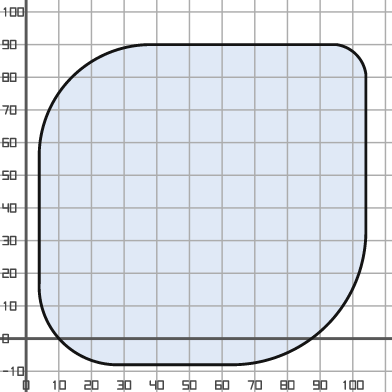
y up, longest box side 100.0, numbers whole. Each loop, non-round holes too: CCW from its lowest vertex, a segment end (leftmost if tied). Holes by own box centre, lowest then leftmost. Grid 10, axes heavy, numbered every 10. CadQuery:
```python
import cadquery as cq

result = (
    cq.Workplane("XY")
    .moveTo(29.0, -8.0)
    .lineTo(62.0, -8.0)
    .threePointArc((92.0, 4.0), (104.0, 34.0))
    .lineTo(104.0, 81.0)
    .threePointArc((101.0, 87.0), (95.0, 90.0))
    .lineTo(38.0, 90.0)
    .threePointArc((14.0, 80.0), (4.0, 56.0))
    .lineTo(4.0, 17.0)
    .threePointArc((11.0, -1.0), (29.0, -8.0))
    .close()
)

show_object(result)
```